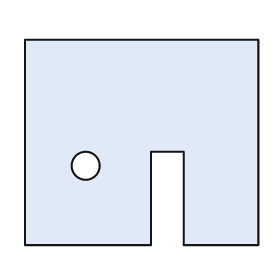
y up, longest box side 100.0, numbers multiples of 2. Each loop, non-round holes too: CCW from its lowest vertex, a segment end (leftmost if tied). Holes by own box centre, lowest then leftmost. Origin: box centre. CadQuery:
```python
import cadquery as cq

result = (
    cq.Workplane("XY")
    .moveTo(-50.0, -44.0)
    .lineTo(4.0, -44.0)
    .lineTo(4.0, -4.0)
    .lineTo(18.0, -4.0)
    .lineTo(18.0, -44.0)
    .lineTo(50.0, -44.0)
    .lineTo(50.0, 44.0)
    .lineTo(-50.0, 44.0)
    .close()
    .moveTo(-24.0, -10.0)
    .circle(6.0)
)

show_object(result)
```